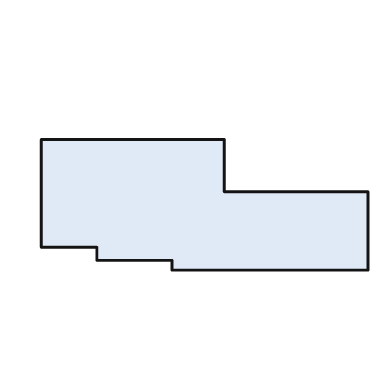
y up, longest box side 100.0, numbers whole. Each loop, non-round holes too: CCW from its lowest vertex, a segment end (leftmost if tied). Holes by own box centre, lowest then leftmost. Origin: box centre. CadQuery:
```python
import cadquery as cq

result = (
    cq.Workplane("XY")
    .moveTo(-10.0, -20.0)
    .lineTo(50.0, -20.0)
    .lineTo(50.0, 4.0)
    .lineTo(6.0, 4.0)
    .lineTo(6.0, 20.0)
    .lineTo(-50.0, 20.0)
    .lineTo(-50.0, -13.0)
    .lineTo(-33.0, -13.0)
    .lineTo(-33.0, -17.0)
    .lineTo(-10.0, -17.0)
    .close()
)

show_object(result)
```